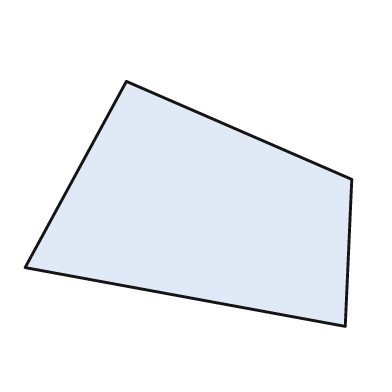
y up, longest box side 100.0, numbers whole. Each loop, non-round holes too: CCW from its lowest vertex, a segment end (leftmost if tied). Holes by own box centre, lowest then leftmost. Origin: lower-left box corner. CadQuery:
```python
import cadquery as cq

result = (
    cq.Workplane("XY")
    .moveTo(98.0, 0.0)
    .lineTo(100.0, 45.0)
    .lineTo(31.0, 75.0)
    .lineTo(0.0, 18.0)
    .close()
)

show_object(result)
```